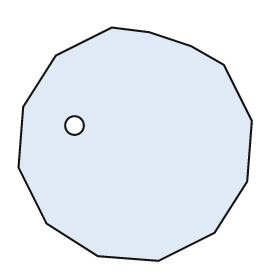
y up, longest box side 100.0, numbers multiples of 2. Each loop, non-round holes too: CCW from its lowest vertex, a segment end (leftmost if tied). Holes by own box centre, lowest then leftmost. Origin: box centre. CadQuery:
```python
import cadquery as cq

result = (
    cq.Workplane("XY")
    .moveTo(10.0, -50.0)
    .lineTo(34.0, -38.0)
    .lineTo(48.0, -16.0)
    .lineTo(50.0, 10.0)
    .lineTo(38.0, 34.0)
    .lineTo(24.0, 42.0)
    .lineTo(6.0, 48.0)
    .lineTo(-10.0, 50.0)
    .lineTo(-34.0, 38.0)
    .lineTo(-48.0, 16.0)
    .lineTo(-50.0, -10.0)
    .lineTo(-38.0, -34.0)
    .lineTo(-16.0, -48.0)
    .close()
    .moveTo(-26.0, 8.0)
    .circle(4.0)
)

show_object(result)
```